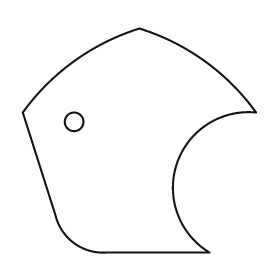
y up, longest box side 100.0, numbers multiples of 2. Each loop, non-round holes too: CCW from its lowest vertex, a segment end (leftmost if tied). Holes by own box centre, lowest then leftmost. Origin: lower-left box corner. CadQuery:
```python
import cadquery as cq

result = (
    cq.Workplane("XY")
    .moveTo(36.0, 0.0)
    .lineTo(80.0, 0.0)
    .threePointArc((66.0, 38.0), (100.0, 60.0))
    .threePointArc((78.0, 82.0), (50.0, 96.0))
    .threePointArc((22.0, 82.0), (0.0, 60.0))
    .lineTo(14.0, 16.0)
    .threePointArc((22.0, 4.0), (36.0, 0.0))
    .close()
    .moveTo(22.0, 56.0)
    .circle(4.0)
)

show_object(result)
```